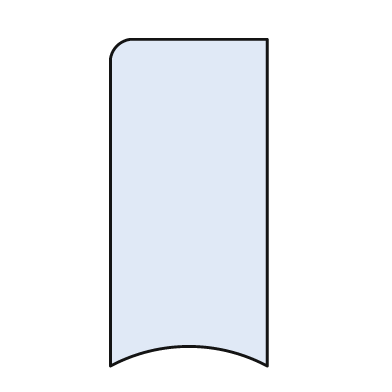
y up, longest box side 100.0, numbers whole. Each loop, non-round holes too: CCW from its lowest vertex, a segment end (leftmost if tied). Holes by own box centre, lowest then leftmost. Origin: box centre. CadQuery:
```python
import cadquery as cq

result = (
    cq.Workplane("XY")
    .moveTo(-24.0, -50.0)
    .threePointArc((0.0, -44.0), (24.0, -50.0))
    .lineTo(24.0, 50.0)
    .lineTo(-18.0, 50.0)
    .threePointArc((-22.0, 48.0), (-24.0, 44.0))
    .close()
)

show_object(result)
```